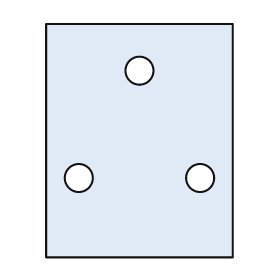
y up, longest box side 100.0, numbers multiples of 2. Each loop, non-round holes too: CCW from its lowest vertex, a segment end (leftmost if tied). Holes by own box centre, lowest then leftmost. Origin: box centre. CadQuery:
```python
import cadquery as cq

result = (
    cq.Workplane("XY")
    .moveTo(-40.0, -50.0)
    .lineTo(40.0, -50.0)
    .lineTo(40.0, 50.0)
    .lineTo(-40.0, 50.0)
    .close()
    .moveTo(-26.0, -16.0)
    .circle(6.0)
    .moveTo(26.0, -16.0)
    .circle(6.0)
    .moveTo(0.0, 30.0)
    .circle(6.0)
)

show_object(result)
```